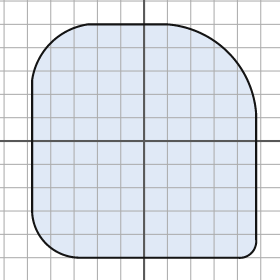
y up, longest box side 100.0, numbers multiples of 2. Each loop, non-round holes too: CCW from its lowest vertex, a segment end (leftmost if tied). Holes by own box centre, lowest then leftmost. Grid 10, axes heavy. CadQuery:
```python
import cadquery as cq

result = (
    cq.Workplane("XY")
    .moveTo(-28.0, -50.0)
    .lineTo(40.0, -50.0)
    .threePointArc((46.0, -48.0), (48.0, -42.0))
    .lineTo(48.0, 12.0)
    .threePointArc((36.0, 38.0), (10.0, 50.0))
    .lineTo(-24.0, 50.0)
    .threePointArc((-40.0, 42.0), (-48.0, 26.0))
    .lineTo(-48.0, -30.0)
    .threePointArc((-42.0, -44.0), (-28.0, -50.0))
    .close()
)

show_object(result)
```